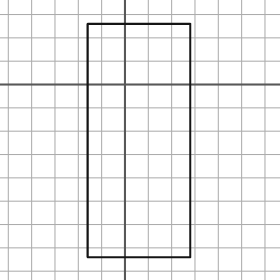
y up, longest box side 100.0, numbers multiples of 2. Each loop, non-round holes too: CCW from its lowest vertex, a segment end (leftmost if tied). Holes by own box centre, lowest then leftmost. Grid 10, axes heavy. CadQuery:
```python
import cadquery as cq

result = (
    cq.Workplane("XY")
    .moveTo(-16.0, -74.0)
    .lineTo(28.0, -74.0)
    .lineTo(28.0, 26.0)
    .lineTo(-16.0, 26.0)
    .close()
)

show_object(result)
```